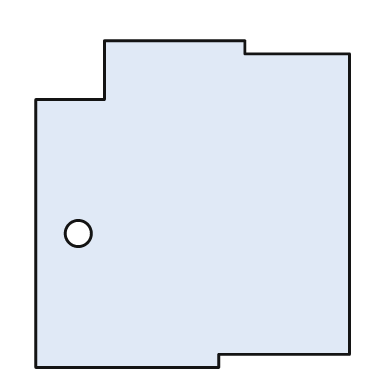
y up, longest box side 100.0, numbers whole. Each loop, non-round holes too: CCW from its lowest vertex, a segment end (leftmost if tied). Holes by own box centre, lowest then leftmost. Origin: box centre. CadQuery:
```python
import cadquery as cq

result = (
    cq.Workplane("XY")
    .moveTo(-48.0, -50.0)
    .lineTo(8.0, -50.0)
    .lineTo(8.0, -46.0)
    .lineTo(48.0, -46.0)
    .lineTo(48.0, 46.0)
    .lineTo(16.0, 46.0)
    .lineTo(16.0, 50.0)
    .lineTo(-27.0, 50.0)
    .lineTo(-27.0, 32.0)
    .lineTo(-48.0, 32.0)
    .close()
    .moveTo(-35.0, -9.0)
    .circle(4.0)
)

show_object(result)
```